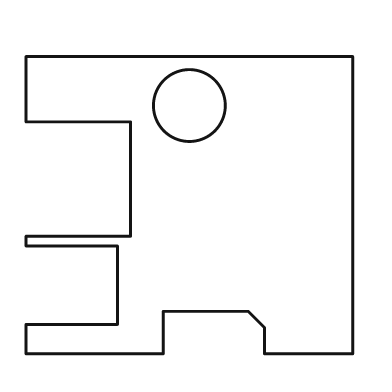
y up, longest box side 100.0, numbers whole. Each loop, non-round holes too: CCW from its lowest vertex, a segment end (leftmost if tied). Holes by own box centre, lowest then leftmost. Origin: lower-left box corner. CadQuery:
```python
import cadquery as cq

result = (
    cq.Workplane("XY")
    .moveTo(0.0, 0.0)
    .lineTo(42.0, 0.0)
    .lineTo(42.0, 13.0)
    .lineTo(68.0, 13.0)
    .lineTo(73.0, 8.0)
    .lineTo(73.0, 0.0)
    .lineTo(100.0, 0.0)
    .lineTo(100.0, 91.0)
    .lineTo(0.0, 91.0)
    .lineTo(0.0, 71.0)
    .lineTo(32.0, 71.0)
    .lineTo(32.0, 36.0)
    .lineTo(0.0, 36.0)
    .lineTo(0.0, 33.0)
    .lineTo(28.0, 33.0)
    .lineTo(28.0, 9.0)
    .lineTo(0.0, 9.0)
    .close()
    .moveTo(50.0, 76.0)
    .circle(11.0)
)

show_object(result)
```